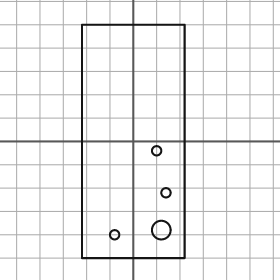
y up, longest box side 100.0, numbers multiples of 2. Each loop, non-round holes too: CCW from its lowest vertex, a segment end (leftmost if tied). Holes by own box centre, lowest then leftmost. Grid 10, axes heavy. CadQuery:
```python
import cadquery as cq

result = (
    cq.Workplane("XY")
    .moveTo(-22.0, -50.0)
    .lineTo(22.0, -50.0)
    .lineTo(22.0, 50.0)
    .lineTo(-22.0, 50.0)
    .close()
    .moveTo(-8.0, -40.0)
    .circle(2.0)
    .moveTo(12.0, -38.0)
    .circle(4.0)
    .moveTo(14.0, -22.0)
    .circle(2.0)
    .moveTo(10.0, -4.0)
    .circle(2.0)
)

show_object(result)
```